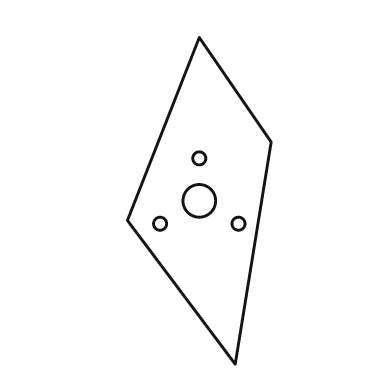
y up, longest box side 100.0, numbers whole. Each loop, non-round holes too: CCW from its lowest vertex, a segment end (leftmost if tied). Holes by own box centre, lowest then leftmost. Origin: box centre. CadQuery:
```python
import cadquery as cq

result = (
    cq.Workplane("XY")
    .moveTo(11.0, -50.0)
    .lineTo(22.0, 18.0)
    .lineTo(0.0, 50.0)
    .lineTo(-22.0, -6.0)
    .close()
    .moveTo(-12.0, -7.0)
    .circle(2.0)
    .moveTo(12.0, -7.0)
    .circle(2.0)
    .moveTo(0.0, 0.0)
    .circle(5.0)
    .moveTo(0.0, 13.0)
    .circle(2.0)
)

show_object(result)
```